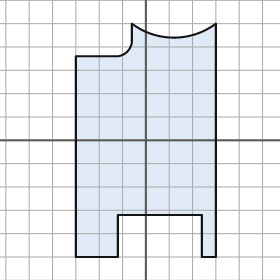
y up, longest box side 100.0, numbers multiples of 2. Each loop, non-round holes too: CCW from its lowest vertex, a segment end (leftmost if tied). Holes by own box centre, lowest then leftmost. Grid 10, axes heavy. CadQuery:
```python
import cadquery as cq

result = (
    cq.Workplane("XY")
    .moveTo(-30.0, -50.0)
    .lineTo(-12.0, -50.0)
    .lineTo(-12.0, -32.0)
    .lineTo(24.0, -32.0)
    .lineTo(24.0, -50.0)
    .lineTo(30.0, -50.0)
    .lineTo(30.0, 50.0)
    .threePointArc((12.0, 44.0), (-6.0, 50.0))
    .lineTo(-6.0, 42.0)
    .threePointArc((-8.0, 38.0), (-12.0, 36.0))
    .lineTo(-30.0, 36.0)
    .close()
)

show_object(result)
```